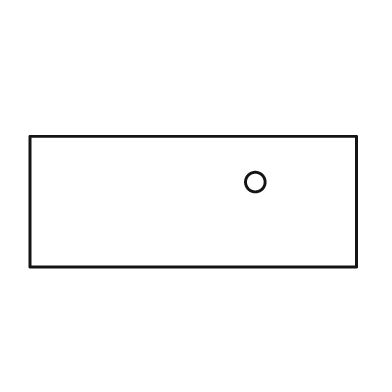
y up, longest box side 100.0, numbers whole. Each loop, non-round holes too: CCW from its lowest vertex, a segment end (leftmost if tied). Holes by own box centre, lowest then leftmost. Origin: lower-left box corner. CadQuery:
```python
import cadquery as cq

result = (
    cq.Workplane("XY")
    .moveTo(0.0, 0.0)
    .lineTo(100.0, 0.0)
    .lineTo(100.0, 40.0)
    .lineTo(0.0, 40.0)
    .close()
    .moveTo(69.0, 26.0)
    .circle(3.0)
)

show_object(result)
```